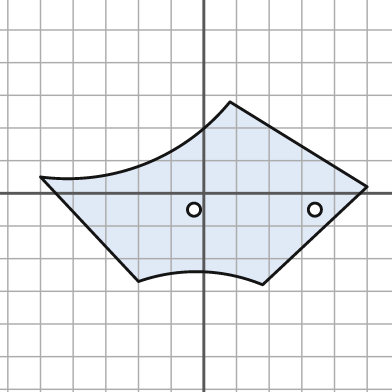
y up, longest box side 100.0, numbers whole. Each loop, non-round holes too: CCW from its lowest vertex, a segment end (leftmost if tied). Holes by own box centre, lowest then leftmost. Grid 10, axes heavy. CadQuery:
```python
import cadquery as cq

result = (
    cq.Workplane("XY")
    .moveTo(18.0, -28.0)
    .lineTo(50.0, 2.0)
    .lineTo(8.0, 28.0)
    .threePointArc((-18.0, 9.0), (-50.0, 5.0))
    .lineTo(-20.0, -27.0)
    .threePointArc((-1.0, -24.0), (18.0, -28.0))
    .close()
    .moveTo(-3.0, -5.0)
    .circle(2.0)
    .moveTo(34.0, -5.0)
    .circle(2.0)
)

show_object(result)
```